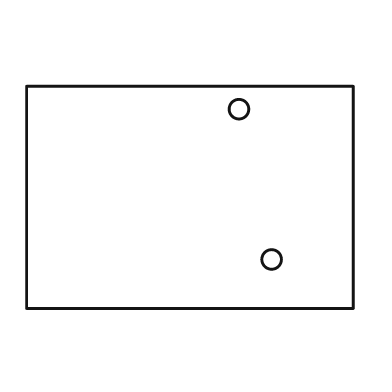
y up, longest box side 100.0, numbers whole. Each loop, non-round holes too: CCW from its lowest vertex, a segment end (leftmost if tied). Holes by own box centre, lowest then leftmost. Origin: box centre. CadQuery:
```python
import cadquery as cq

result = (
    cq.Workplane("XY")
    .moveTo(-50.0, -34.0)
    .lineTo(50.0, -34.0)
    .lineTo(50.0, 34.0)
    .lineTo(-50.0, 34.0)
    .close()
    .moveTo(25.0, -19.0)
    .circle(3.0)
    .moveTo(15.0, 27.0)
    .circle(3.0)
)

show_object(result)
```